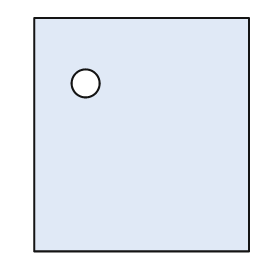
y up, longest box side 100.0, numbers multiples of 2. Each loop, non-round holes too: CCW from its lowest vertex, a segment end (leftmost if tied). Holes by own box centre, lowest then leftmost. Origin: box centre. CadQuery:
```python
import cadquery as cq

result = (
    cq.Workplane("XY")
    .moveTo(-46.0, -50.0)
    .lineTo(46.0, -50.0)
    .lineTo(46.0, 50.0)
    .lineTo(-46.0, 50.0)
    .close()
    .moveTo(-24.0, 22.0)
    .circle(6.0)
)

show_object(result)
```